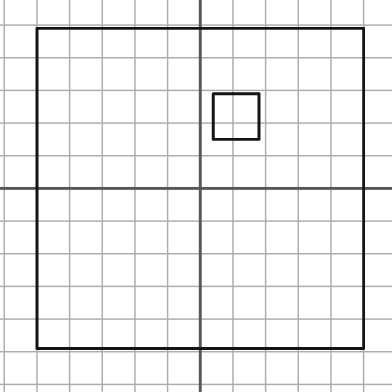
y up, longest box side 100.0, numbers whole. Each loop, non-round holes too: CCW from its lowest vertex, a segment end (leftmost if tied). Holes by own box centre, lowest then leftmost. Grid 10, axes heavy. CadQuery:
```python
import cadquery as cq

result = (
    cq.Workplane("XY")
    .moveTo(-50.0, -49.0)
    .lineTo(50.0, -49.0)
    .lineTo(50.0, 49.0)
    .lineTo(-50.0, 49.0)
    .close()
    .moveTo(4.0, 15.0)
    .lineTo(18.0, 15.0)
    .lineTo(18.0, 29.0)
    .lineTo(4.0, 29.0)
    .close()
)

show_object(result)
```